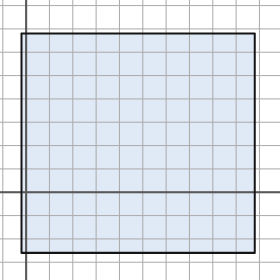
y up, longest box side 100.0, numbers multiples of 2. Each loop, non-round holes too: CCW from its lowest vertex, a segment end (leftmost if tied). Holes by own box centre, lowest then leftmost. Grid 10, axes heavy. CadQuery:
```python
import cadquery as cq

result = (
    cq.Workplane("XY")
    .moveTo(-2.0, -26.0)
    .lineTo(98.0, -26.0)
    .lineTo(98.0, 68.0)
    .lineTo(-2.0, 68.0)
    .close()
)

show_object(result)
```